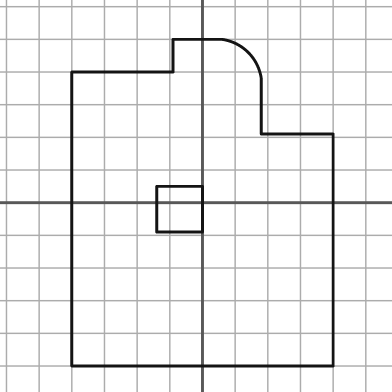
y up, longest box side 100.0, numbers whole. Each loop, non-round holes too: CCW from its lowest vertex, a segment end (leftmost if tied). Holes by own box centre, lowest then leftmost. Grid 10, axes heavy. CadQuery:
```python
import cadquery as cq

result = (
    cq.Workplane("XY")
    .moveTo(-40.0, -50.0)
    .lineTo(40.0, -50.0)
    .lineTo(40.0, 21.0)
    .lineTo(18.0, 21.0)
    .lineTo(18.0, 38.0)
    .threePointArc((14.0, 46.0), (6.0, 50.0))
    .lineTo(-9.0, 50.0)
    .lineTo(-9.0, 40.0)
    .lineTo(-40.0, 40.0)
    .close()
    .moveTo(-14.0, -9.0)
    .lineTo(0.0, -9.0)
    .lineTo(0.0, 5.0)
    .lineTo(-14.0, 5.0)
    .close()
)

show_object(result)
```